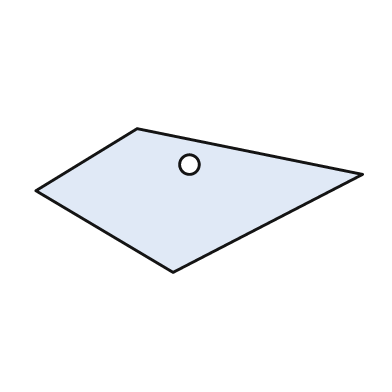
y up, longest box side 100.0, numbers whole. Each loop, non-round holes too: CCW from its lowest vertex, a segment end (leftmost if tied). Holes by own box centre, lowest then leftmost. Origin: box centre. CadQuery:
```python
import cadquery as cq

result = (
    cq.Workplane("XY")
    .moveTo(-8.0, -22.0)
    .lineTo(50.0, 8.0)
    .lineTo(-19.0, 22.0)
    .lineTo(-50.0, 3.0)
    .close()
    .moveTo(-3.0, 11.0)
    .circle(3.0)
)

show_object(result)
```